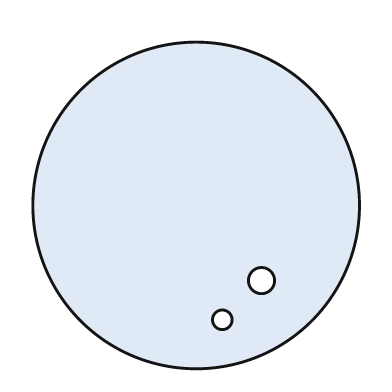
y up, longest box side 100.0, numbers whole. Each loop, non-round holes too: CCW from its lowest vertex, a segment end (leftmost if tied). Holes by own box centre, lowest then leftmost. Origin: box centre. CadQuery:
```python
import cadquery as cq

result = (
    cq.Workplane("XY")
    .moveTo(0.0, 0.0)
    .circle(50.0)
    .moveTo(8.0, -35.0)
    .circle(3.0)
    .moveTo(20.0, -23.0)
    .circle(4.0)
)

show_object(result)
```